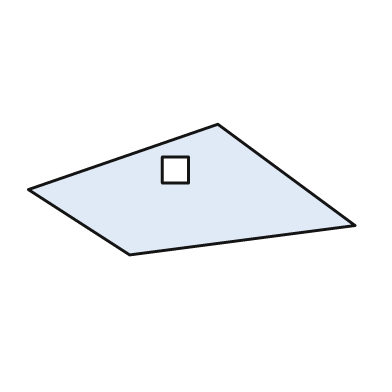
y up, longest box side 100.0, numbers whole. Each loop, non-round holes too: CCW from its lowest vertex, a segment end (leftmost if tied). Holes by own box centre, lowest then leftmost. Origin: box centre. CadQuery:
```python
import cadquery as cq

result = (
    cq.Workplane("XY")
    .moveTo(-19.0, -20.0)
    .lineTo(50.0, -11.0)
    .lineTo(8.0, 20.0)
    .lineTo(-50.0, 0.0)
    .close()
    .moveTo(-9.0, 2.0)
    .lineTo(-1.0, 2.0)
    .lineTo(-1.0, 10.0)
    .lineTo(-9.0, 10.0)
    .close()
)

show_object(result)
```